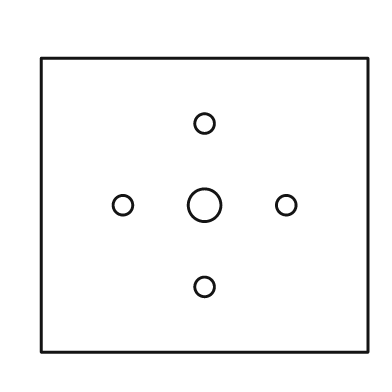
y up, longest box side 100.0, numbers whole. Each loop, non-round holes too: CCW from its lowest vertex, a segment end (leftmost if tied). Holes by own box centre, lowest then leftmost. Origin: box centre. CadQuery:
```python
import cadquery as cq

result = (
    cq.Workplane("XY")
    .moveTo(-50.0, -45.0)
    .lineTo(50.0, -45.0)
    .lineTo(50.0, 45.0)
    .lineTo(-50.0, 45.0)
    .close()
    .moveTo(0.0, -25.0)
    .circle(3.0)
    .moveTo(-25.0, 0.0)
    .circle(3.0)
    .moveTo(0.0, 0.0)
    .circle(5.0)
    .moveTo(25.0, 0.0)
    .circle(3.0)
    .moveTo(0.0, 25.0)
    .circle(3.0)
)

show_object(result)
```